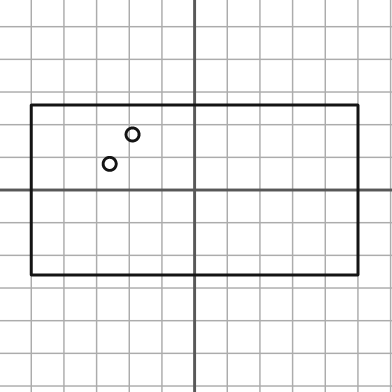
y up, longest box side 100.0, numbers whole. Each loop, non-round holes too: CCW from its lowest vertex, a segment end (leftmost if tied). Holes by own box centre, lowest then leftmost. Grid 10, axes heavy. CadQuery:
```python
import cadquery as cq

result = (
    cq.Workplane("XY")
    .moveTo(-50.0, -26.0)
    .lineTo(50.0, -26.0)
    .lineTo(50.0, 26.0)
    .lineTo(-50.0, 26.0)
    .close()
    .moveTo(-26.0, 8.0)
    .circle(2.0)
    .moveTo(-19.0, 17.0)
    .circle(2.0)
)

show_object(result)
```